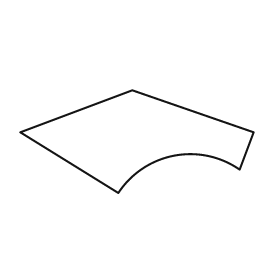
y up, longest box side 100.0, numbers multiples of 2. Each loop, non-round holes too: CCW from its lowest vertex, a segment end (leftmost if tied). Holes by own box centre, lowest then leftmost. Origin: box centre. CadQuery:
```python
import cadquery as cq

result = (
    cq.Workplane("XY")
    .moveTo(-8.0, -22.0)
    .threePointArc((16.0, -6.0), (44.0, -12.0))
    .lineTo(50.0, 4.0)
    .lineTo(-2.0, 22.0)
    .lineTo(-50.0, 4.0)
    .close()
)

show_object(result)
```